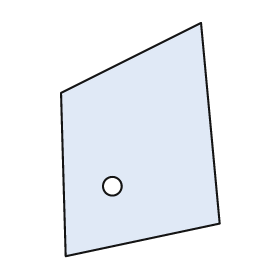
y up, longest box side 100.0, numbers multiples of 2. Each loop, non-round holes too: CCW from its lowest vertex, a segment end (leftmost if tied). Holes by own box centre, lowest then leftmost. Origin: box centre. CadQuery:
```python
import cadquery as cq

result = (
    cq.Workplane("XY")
    .moveTo(-32.0, -50.0)
    .lineTo(34.0, -36.0)
    .lineTo(26.0, 50.0)
    .lineTo(-34.0, 20.0)
    .close()
    .moveTo(-12.0, -20.0)
    .circle(4.0)
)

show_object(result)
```